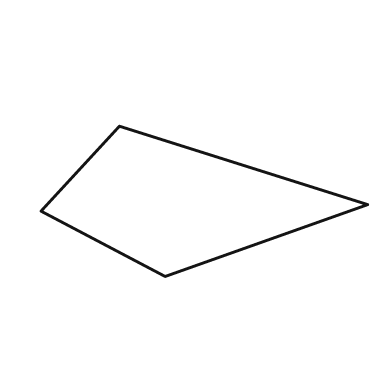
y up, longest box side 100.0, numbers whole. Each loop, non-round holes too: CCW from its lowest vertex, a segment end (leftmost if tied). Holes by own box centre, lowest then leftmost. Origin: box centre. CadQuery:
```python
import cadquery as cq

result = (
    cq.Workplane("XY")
    .moveTo(-12.0, -23.0)
    .lineTo(50.0, -1.0)
    .lineTo(-26.0, 23.0)
    .lineTo(-50.0, -3.0)
    .close()
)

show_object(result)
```